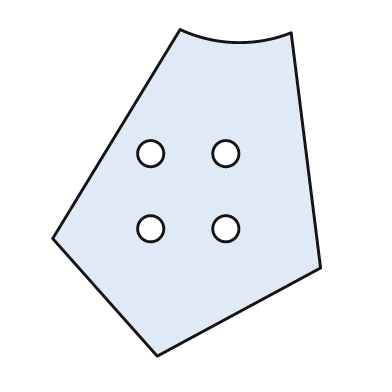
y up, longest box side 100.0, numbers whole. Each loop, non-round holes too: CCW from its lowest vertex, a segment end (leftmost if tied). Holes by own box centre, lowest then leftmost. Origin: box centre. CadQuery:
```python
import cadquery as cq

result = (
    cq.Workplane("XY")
    .moveTo(-9.0, -50.0)
    .lineTo(41.0, -23.0)
    .lineTo(32.0, 49.0)
    .threePointArc((15.0, 46.0), (-2.0, 50.0))
    .lineTo(-41.0, -14.0)
    .close()
    .moveTo(-11.0, -11.0)
    .circle(4.0)
    .moveTo(12.0, -11.0)
    .circle(4.0)
    .moveTo(-11.0, 12.0)
    .circle(4.0)
    .moveTo(12.0, 12.0)
    .circle(4.0)
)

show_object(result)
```